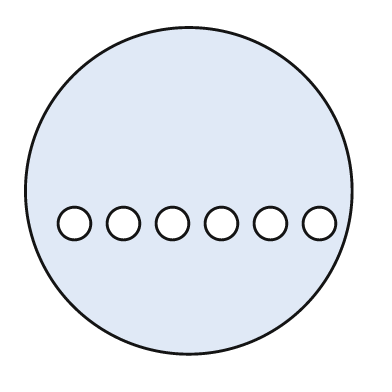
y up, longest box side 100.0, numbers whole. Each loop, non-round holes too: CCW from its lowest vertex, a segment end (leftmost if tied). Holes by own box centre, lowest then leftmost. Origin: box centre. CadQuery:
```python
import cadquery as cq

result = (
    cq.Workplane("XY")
    .moveTo(0.0, 0.0)
    .circle(50.0)
    .moveTo(-35.0, -10.0)
    .circle(5.0)
    .moveTo(-20.0, -10.0)
    .circle(5.0)
    .moveTo(-5.0, -10.0)
    .circle(5.0)
    .moveTo(10.0, -10.0)
    .circle(5.0)
    .moveTo(25.0, -10.0)
    .circle(5.0)
    .moveTo(40.0, -10.0)
    .circle(5.0)
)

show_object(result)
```